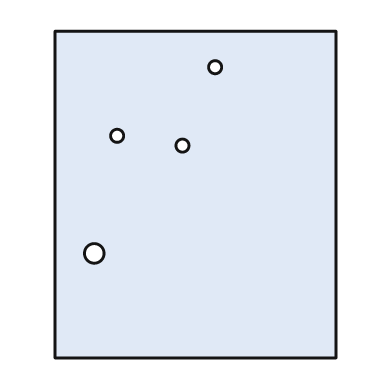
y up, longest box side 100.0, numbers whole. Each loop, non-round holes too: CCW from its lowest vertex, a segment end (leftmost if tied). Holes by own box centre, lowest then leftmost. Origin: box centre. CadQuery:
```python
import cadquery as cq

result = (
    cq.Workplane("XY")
    .moveTo(-43.0, -50.0)
    .lineTo(43.0, -50.0)
    .lineTo(43.0, 50.0)
    .lineTo(-43.0, 50.0)
    .close()
    .moveTo(-31.0, -18.0)
    .circle(3.0)
    .moveTo(-4.0, 15.0)
    .circle(2.0)
    .moveTo(-24.0, 18.0)
    .circle(2.0)
    .moveTo(6.0, 39.0)
    .circle(2.0)
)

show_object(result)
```